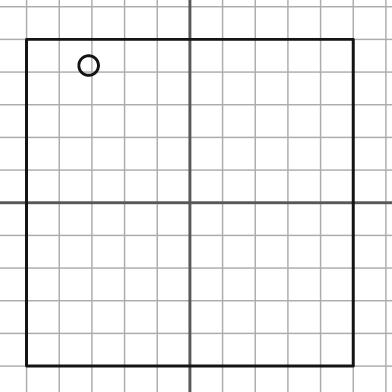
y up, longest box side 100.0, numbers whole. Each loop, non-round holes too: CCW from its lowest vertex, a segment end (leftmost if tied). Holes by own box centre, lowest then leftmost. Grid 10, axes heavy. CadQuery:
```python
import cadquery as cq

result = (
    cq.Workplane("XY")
    .moveTo(-50.0, -50.0)
    .lineTo(50.0, -50.0)
    .lineTo(50.0, 50.0)
    .lineTo(-50.0, 50.0)
    .close()
    .moveTo(-31.0, 42.0)
    .circle(3.0)
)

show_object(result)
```